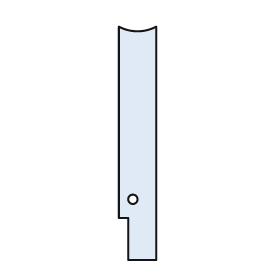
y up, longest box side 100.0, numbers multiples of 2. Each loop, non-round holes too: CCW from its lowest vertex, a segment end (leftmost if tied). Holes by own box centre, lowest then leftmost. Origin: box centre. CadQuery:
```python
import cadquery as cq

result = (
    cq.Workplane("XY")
    .moveTo(-4.0, -50.0)
    .lineTo(8.0, -50.0)
    .lineTo(8.0, 50.0)
    .threePointArc((0.0, 48.0), (-8.0, 50.0))
    .lineTo(-8.0, -32.0)
    .lineTo(-4.0, -32.0)
    .close()
    .moveTo(-2.0, -24.0)
    .circle(2.0)
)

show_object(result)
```